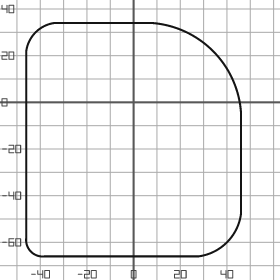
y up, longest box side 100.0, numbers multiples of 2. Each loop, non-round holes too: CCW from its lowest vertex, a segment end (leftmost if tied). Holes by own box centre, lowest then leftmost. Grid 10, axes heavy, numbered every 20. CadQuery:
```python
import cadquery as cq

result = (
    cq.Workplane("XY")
    .moveTo(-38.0, -66.0)
    .lineTo(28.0, -66.0)
    .threePointArc((40.0, -60.0), (46.0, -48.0))
    .lineTo(46.0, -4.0)
    .threePointArc((34.0, 22.0), (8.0, 34.0))
    .lineTo(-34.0, 34.0)
    .threePointArc((-42.0, 30.0), (-46.0, 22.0))
    .lineTo(-46.0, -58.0)
    .threePointArc((-44.0, -64.0), (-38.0, -66.0))
    .close()
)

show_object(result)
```